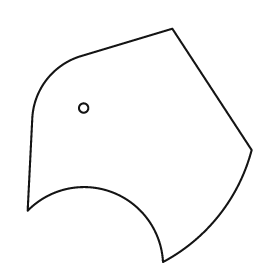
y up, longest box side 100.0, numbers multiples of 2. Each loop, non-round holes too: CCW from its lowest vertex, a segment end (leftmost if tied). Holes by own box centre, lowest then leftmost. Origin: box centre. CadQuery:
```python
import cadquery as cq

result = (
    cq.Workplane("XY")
    .moveTo(10.0, -50.0)
    .threePointArc((34.0, -30.0), (48.0, -2.0))
    .lineTo(14.0, 50.0)
    .lineTo(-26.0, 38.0)
    .threePointArc((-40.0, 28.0), (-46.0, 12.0))
    .lineTo(-48.0, -28.0)
    .threePointArc((-12.0, -20.0), (10.0, -50.0))
    .close()
    .moveTo(-24.0, 16.0)
    .circle(2.0)
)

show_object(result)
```